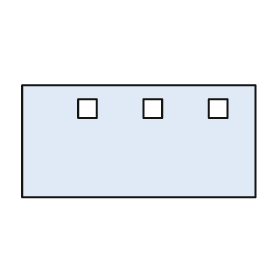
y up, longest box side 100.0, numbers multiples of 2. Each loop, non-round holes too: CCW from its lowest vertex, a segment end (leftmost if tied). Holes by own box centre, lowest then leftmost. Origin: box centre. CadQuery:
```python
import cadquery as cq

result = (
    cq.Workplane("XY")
    .moveTo(-50.0, -24.0)
    .lineTo(50.0, -24.0)
    .lineTo(50.0, 24.0)
    .lineTo(-50.0, 24.0)
    .close()
    .moveTo(-26.0, 10.0)
    .lineTo(-18.0, 10.0)
    .lineTo(-18.0, 18.0)
    .lineTo(-26.0, 18.0)
    .close()
    .moveTo(2.0, 10.0)
    .lineTo(10.0, 10.0)
    .lineTo(10.0, 18.0)
    .lineTo(2.0, 18.0)
    .close()
    .moveTo(30.0, 10.0)
    .lineTo(38.0, 10.0)
    .lineTo(38.0, 18.0)
    .lineTo(30.0, 18.0)
    .close()
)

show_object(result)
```